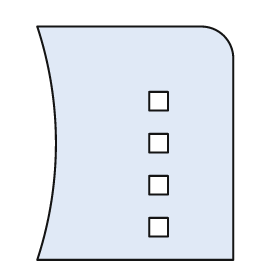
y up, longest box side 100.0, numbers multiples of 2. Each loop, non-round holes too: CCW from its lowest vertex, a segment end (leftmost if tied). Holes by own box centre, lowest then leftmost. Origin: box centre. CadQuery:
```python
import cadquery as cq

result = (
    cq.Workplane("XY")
    .moveTo(-42.0, -50.0)
    .lineTo(42.0, -50.0)
    .lineTo(42.0, 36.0)
    .threePointArc((38.0, 46.0), (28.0, 50.0))
    .lineTo(-42.0, 50.0)
    .threePointArc((-34.0, 0.0), (-42.0, -50.0))
    .close()
    .moveTo(6.0, -40.0)
    .lineTo(14.0, -40.0)
    .lineTo(14.0, -32.0)
    .lineTo(6.0, -32.0)
    .close()
    .moveTo(6.0, -22.0)
    .lineTo(14.0, -22.0)
    .lineTo(14.0, -14.0)
    .lineTo(6.0, -14.0)
    .close()
    .moveTo(6.0, -4.0)
    .lineTo(14.0, -4.0)
    .lineTo(14.0, 4.0)
    .lineTo(6.0, 4.0)
    .close()
    .moveTo(6.0, 14.0)
    .lineTo(14.0, 14.0)
    .lineTo(14.0, 22.0)
    .lineTo(6.0, 22.0)
    .close()
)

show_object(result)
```